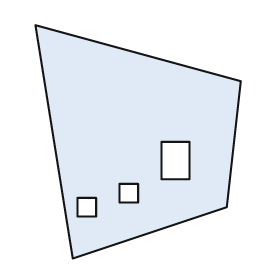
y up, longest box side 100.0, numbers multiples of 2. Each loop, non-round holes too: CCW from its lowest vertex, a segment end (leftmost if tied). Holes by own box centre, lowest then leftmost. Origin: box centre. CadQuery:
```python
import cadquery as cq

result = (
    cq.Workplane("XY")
    .moveTo(-28.0, -50.0)
    .lineTo(38.0, -28.0)
    .lineTo(44.0, 26.0)
    .lineTo(-44.0, 50.0)
    .close()
    .moveTo(-26.0, -32.0)
    .lineTo(-18.0, -32.0)
    .lineTo(-18.0, -24.0)
    .lineTo(-26.0, -24.0)
    .close()
    .moveTo(-8.0, -26.0)
    .lineTo(0.0, -26.0)
    .lineTo(0.0, -18.0)
    .lineTo(-8.0, -18.0)
    .close()
    .moveTo(10.0, -16.0)
    .lineTo(22.0, -16.0)
    .lineTo(22.0, 0.0)
    .lineTo(10.0, 0.0)
    .close()
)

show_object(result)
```